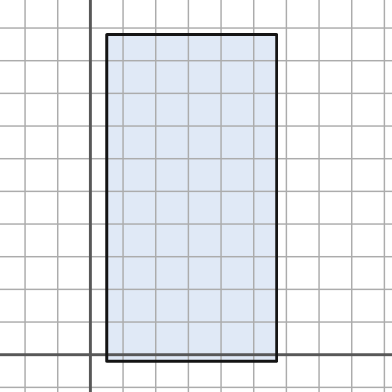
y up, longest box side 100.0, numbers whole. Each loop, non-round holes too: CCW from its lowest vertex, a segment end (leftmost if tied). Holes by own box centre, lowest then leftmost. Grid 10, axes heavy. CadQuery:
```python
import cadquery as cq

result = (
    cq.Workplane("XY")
    .moveTo(5.0, -2.0)
    .lineTo(57.0, -2.0)
    .lineTo(57.0, 98.0)
    .lineTo(5.0, 98.0)
    .close()
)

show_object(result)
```